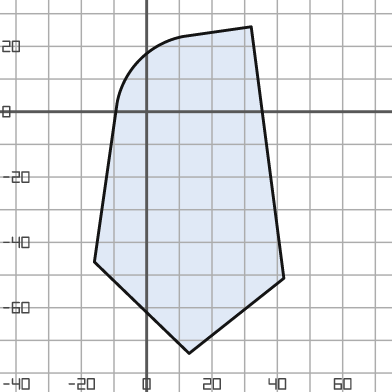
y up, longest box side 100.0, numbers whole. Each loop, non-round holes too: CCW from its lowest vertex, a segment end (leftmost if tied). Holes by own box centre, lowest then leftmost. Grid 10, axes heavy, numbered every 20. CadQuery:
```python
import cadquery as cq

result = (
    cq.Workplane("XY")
    .moveTo(13.0, -74.0)
    .lineTo(42.0, -51.0)
    .lineTo(32.0, 26.0)
    .lineTo(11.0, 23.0)
    .threePointArc((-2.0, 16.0), (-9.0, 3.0))
    .lineTo(-16.0, -46.0)
    .close()
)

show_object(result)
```